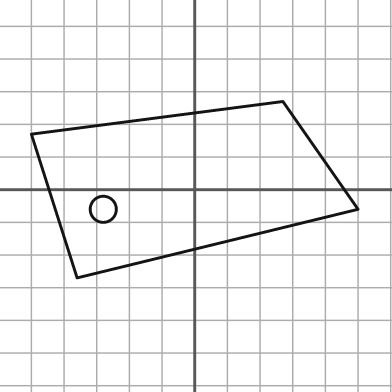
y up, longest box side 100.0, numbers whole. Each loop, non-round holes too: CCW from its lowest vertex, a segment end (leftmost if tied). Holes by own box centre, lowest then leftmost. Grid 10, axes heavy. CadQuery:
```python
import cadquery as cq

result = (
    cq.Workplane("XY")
    .moveTo(-36.0, -27.0)
    .lineTo(50.0, -6.0)
    .lineTo(27.0, 27.0)
    .lineTo(-50.0, 17.0)
    .close()
    .moveTo(-28.0, -6.0)
    .circle(4.0)
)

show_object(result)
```